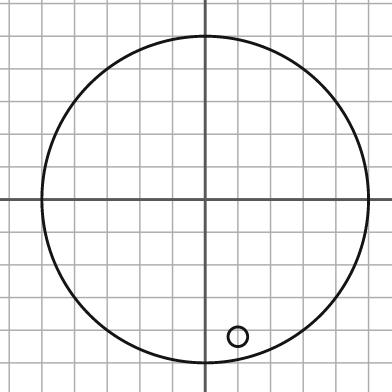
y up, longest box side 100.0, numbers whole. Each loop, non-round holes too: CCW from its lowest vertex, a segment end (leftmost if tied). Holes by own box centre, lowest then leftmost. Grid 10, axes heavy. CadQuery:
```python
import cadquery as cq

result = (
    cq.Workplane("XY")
    .moveTo(0.0, 0.0)
    .circle(50.0)
    .moveTo(10.0, -42.0)
    .circle(3.0)
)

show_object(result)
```